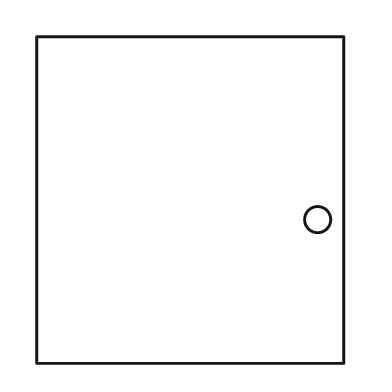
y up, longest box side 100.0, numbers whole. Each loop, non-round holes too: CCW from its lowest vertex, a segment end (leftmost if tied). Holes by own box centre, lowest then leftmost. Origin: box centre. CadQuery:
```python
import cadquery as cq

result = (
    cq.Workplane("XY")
    .moveTo(-47.0, -50.0)
    .lineTo(47.0, -50.0)
    .lineTo(47.0, 50.0)
    .lineTo(-47.0, 50.0)
    .close()
    .moveTo(39.0, -6.0)
    .circle(4.0)
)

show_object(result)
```